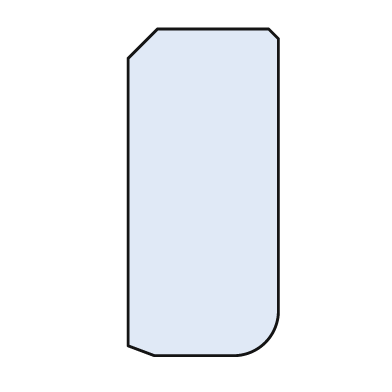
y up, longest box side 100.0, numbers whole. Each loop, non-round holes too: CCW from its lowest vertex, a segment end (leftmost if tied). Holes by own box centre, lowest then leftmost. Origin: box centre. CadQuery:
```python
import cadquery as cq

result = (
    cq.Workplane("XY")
    .moveTo(-15.0, -50.0)
    .lineTo(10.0, -50.0)
    .threePointArc((19.0, -46.0), (23.0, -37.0))
    .lineTo(23.0, 47.0)
    .lineTo(20.0, 50.0)
    .lineTo(-14.0, 50.0)
    .lineTo(-23.0, 41.0)
    .lineTo(-23.0, -47.0)
    .close()
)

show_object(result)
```